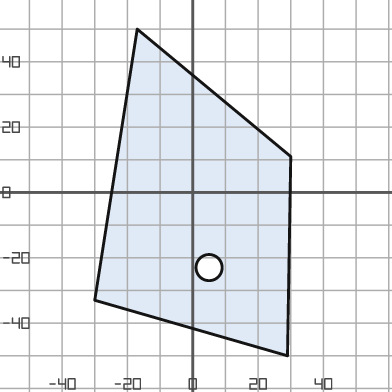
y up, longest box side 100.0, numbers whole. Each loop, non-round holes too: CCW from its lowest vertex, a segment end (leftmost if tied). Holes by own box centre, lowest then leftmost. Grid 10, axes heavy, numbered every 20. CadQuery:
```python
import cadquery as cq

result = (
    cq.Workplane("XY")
    .moveTo(29.0, -50.0)
    .lineTo(30.0, 11.0)
    .lineTo(-17.0, 50.0)
    .lineTo(-30.0, -33.0)
    .close()
    .moveTo(5.0, -23.0)
    .circle(4.0)
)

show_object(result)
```